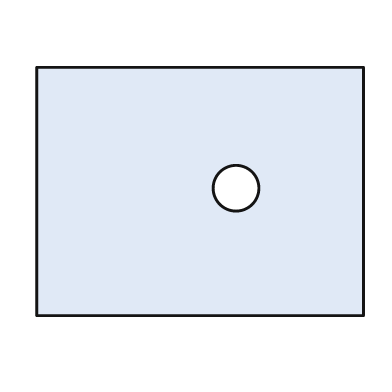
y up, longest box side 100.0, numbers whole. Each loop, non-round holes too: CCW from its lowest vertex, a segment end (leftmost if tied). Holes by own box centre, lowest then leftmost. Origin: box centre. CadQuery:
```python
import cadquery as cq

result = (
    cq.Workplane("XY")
    .moveTo(-50.0, -38.0)
    .lineTo(50.0, -38.0)
    .lineTo(50.0, 38.0)
    .lineTo(-50.0, 38.0)
    .close()
    .moveTo(11.0, 1.0)
    .circle(7.0)
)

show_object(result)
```